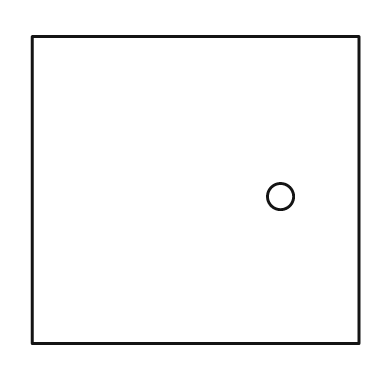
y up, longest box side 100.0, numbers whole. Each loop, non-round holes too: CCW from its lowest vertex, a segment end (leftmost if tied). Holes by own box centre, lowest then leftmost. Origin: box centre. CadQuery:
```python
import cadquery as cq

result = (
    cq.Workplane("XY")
    .moveTo(-50.0, -47.0)
    .lineTo(50.0, -47.0)
    .lineTo(50.0, 47.0)
    .lineTo(-50.0, 47.0)
    .close()
    .moveTo(26.0, -2.0)
    .circle(4.0)
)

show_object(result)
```